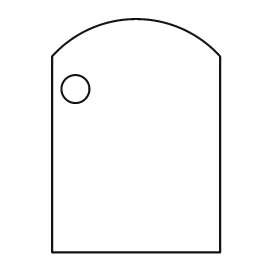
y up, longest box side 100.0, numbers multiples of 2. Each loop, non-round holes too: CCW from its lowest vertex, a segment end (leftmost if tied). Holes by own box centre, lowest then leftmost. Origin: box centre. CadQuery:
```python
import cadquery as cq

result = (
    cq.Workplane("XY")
    .moveTo(-36.0, -50.0)
    .lineTo(36.0, -50.0)
    .lineTo(36.0, 34.0)
    .threePointArc((0.0, 50.0), (-36.0, 34.0))
    .close()
    .moveTo(-26.0, 20.0)
    .circle(6.0)
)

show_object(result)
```